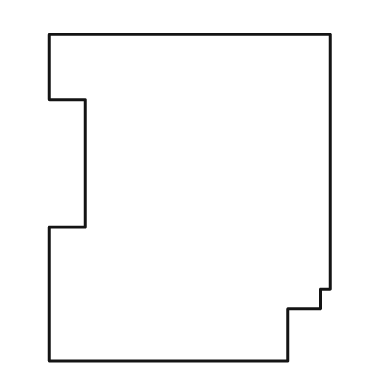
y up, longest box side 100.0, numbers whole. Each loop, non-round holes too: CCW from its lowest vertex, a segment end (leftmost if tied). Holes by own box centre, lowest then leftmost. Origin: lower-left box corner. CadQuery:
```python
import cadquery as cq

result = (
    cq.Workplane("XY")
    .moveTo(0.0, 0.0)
    .lineTo(73.0, 0.0)
    .lineTo(73.0, 16.0)
    .lineTo(83.0, 16.0)
    .lineTo(83.0, 22.0)
    .lineTo(86.0, 22.0)
    .lineTo(86.0, 100.0)
    .lineTo(0.0, 100.0)
    .lineTo(0.0, 80.0)
    .lineTo(11.0, 80.0)
    .lineTo(11.0, 41.0)
    .lineTo(0.0, 41.0)
    .close()
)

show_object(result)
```